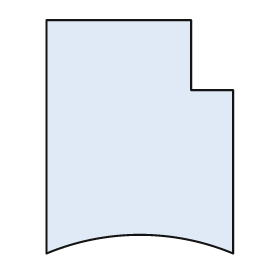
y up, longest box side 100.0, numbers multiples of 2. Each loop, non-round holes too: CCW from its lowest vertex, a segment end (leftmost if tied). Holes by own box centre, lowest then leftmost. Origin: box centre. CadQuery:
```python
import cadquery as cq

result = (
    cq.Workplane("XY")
    .moveTo(-40.0, -50.0)
    .threePointArc((0.0, -42.0), (40.0, -50.0))
    .lineTo(40.0, 20.0)
    .lineTo(22.0, 20.0)
    .lineTo(22.0, 50.0)
    .lineTo(-40.0, 50.0)
    .close()
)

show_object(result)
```